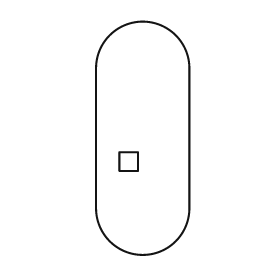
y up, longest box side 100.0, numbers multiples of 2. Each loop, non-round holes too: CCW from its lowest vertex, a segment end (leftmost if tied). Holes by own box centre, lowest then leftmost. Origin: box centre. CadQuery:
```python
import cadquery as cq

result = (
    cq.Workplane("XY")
    .moveTo(-20.0, -30.0)
    .threePointArc((0.0, -50.0), (20.0, -30.0))
    .lineTo(20.0, 30.0)
    .threePointArc((0.0, 50.0), (-20.0, 30.0))
    .close()
    .moveTo(-10.0, -14.0)
    .lineTo(-2.0, -14.0)
    .lineTo(-2.0, -6.0)
    .lineTo(-10.0, -6.0)
    .close()
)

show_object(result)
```